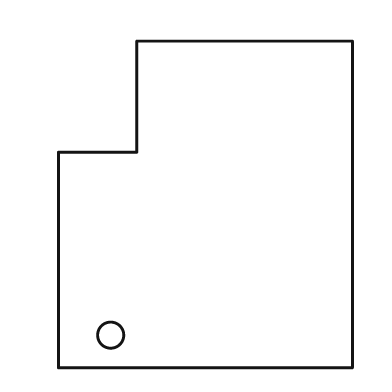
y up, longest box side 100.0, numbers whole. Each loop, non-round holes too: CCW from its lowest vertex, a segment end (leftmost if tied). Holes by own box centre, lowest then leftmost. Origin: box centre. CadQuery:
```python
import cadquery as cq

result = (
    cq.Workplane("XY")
    .moveTo(-45.0, -50.0)
    .lineTo(45.0, -50.0)
    .lineTo(45.0, 50.0)
    .lineTo(-21.0, 50.0)
    .lineTo(-21.0, 16.0)
    .lineTo(-45.0, 16.0)
    .close()
    .moveTo(-29.0, -40.0)
    .circle(4.0)
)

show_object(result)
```